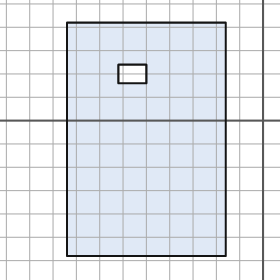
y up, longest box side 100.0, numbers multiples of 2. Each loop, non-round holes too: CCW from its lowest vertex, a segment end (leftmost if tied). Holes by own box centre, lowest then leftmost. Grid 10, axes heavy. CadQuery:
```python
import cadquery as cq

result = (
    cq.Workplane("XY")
    .moveTo(-84.0, -58.0)
    .lineTo(-16.0, -58.0)
    .lineTo(-16.0, 42.0)
    .lineTo(-84.0, 42.0)
    .close()
    .moveTo(-62.0, 16.0)
    .lineTo(-50.0, 16.0)
    .lineTo(-50.0, 24.0)
    .lineTo(-62.0, 24.0)
    .close()
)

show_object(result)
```